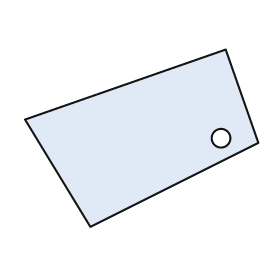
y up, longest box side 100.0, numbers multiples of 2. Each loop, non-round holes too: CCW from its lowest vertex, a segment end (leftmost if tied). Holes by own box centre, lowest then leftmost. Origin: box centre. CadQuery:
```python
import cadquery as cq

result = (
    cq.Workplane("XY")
    .moveTo(-22.0, -38.0)
    .lineTo(50.0, -2.0)
    .lineTo(36.0, 38.0)
    .lineTo(-50.0, 8.0)
    .close()
    .moveTo(34.0, 0.0)
    .circle(4.0)
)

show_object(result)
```